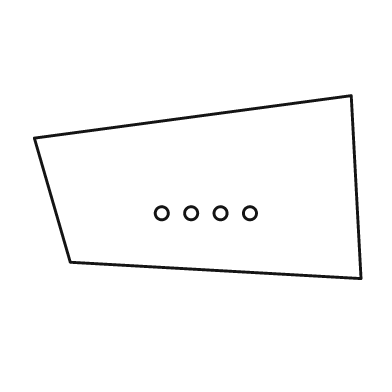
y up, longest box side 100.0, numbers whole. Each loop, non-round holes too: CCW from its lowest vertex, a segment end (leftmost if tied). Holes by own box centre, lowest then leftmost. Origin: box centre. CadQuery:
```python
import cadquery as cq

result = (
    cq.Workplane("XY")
    .moveTo(50.0, -28.0)
    .lineTo(47.0, 28.0)
    .lineTo(-50.0, 15.0)
    .lineTo(-39.0, -23.0)
    .close()
    .moveTo(-11.0, -8.0)
    .circle(2.0)
    .moveTo(-2.0, -8.0)
    .circle(2.0)
    .moveTo(7.0, -8.0)
    .circle(2.0)
    .moveTo(16.0, -8.0)
    .circle(2.0)
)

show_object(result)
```